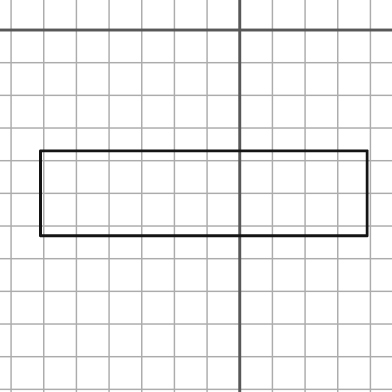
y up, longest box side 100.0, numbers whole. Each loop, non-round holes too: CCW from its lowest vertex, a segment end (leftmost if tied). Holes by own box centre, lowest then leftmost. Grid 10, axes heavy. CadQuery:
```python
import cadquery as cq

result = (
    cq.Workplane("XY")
    .moveTo(-61.0, -63.0)
    .lineTo(39.0, -63.0)
    .lineTo(39.0, -37.0)
    .lineTo(-61.0, -37.0)
    .close()
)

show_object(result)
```